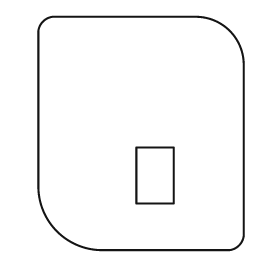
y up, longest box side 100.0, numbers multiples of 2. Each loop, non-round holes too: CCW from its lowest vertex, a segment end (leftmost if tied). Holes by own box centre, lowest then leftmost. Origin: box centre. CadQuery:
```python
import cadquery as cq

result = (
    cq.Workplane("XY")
    .moveTo(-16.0, -50.0)
    .lineTo(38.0, -50.0)
    .threePointArc((42.0, -48.0), (44.0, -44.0))
    .lineTo(44.0, 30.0)
    .threePointArc((38.0, 44.0), (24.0, 50.0))
    .lineTo(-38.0, 50.0)
    .threePointArc((-42.0, 48.0), (-44.0, 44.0))
    .lineTo(-44.0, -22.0)
    .threePointArc((-36.0, -42.0), (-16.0, -50.0))
    .close()
    .moveTo(-2.0, -30.0)
    .lineTo(14.0, -30.0)
    .lineTo(14.0, -6.0)
    .lineTo(-2.0, -6.0)
    .close()
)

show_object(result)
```